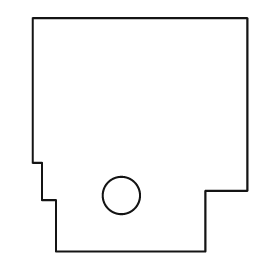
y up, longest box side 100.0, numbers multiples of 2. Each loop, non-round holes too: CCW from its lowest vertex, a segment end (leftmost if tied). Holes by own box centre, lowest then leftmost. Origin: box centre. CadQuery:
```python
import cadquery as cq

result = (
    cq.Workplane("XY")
    .moveTo(-36.0, -50.0)
    .lineTo(28.0, -50.0)
    .lineTo(28.0, -24.0)
    .lineTo(46.0, -24.0)
    .lineTo(46.0, 50.0)
    .lineTo(-46.0, 50.0)
    .lineTo(-46.0, -12.0)
    .lineTo(-42.0, -12.0)
    .lineTo(-42.0, -28.0)
    .lineTo(-36.0, -28.0)
    .close()
    .moveTo(-8.0, -26.0)
    .circle(8.0)
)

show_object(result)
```